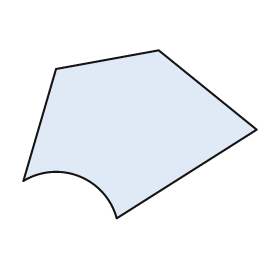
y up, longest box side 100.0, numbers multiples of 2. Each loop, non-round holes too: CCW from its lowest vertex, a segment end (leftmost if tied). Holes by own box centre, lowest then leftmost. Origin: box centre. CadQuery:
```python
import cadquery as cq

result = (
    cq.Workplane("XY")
    .moveTo(-10.0, -36.0)
    .lineTo(50.0, 2.0)
    .lineTo(8.0, 36.0)
    .lineTo(-36.0, 28.0)
    .lineTo(-50.0, -20.0)
    .threePointArc((-26.0, -18.0), (-10.0, -36.0))
    .close()
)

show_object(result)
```